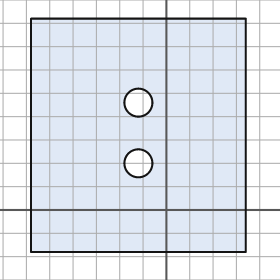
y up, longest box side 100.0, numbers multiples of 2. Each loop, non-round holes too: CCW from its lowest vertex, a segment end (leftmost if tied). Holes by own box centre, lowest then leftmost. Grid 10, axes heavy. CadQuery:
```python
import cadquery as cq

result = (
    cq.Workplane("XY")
    .moveTo(-58.0, -18.0)
    .lineTo(34.0, -18.0)
    .lineTo(34.0, 82.0)
    .lineTo(-58.0, 82.0)
    .close()
    .moveTo(-12.0, 20.0)
    .circle(6.0)
    .moveTo(-12.0, 46.0)
    .circle(6.0)
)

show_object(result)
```